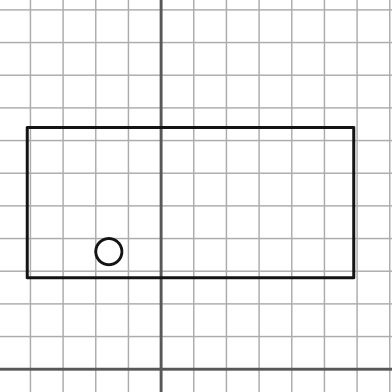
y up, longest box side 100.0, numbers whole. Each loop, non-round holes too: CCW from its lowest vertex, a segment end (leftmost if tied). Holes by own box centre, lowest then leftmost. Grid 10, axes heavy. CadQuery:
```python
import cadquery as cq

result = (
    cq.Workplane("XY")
    .moveTo(-41.0, 28.0)
    .lineTo(59.0, 28.0)
    .lineTo(59.0, 74.0)
    .lineTo(-41.0, 74.0)
    .close()
    .moveTo(-16.0, 36.0)
    .circle(4.0)
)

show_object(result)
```